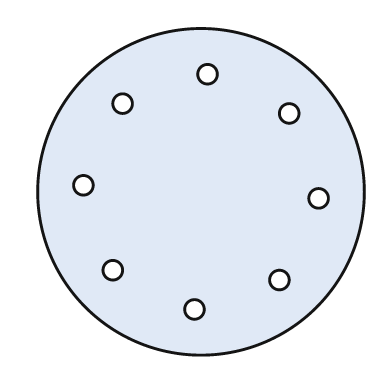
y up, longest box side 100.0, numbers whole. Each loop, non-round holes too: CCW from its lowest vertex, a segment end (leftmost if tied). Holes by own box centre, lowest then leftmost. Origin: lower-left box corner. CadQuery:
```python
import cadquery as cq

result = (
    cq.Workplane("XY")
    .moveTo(50.0, 50.0)
    .circle(50.0)
    .moveTo(48.0, 14.0)
    .circle(3.0)
    .moveTo(74.0, 23.0)
    .circle(3.0)
    .moveTo(23.0, 26.0)
    .circle(3.0)
    .moveTo(86.0, 48.0)
    .circle(3.0)
    .moveTo(14.0, 52.0)
    .circle(3.0)
    .moveTo(77.0, 74.0)
    .circle(3.0)
    .moveTo(26.0, 77.0)
    .circle(3.0)
    .moveTo(52.0, 86.0)
    .circle(3.0)
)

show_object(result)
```